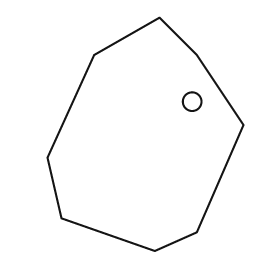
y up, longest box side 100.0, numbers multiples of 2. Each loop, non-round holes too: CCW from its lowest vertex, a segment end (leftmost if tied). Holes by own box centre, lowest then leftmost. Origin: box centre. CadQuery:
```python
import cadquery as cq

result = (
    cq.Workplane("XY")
    .moveTo(4.0, -50.0)
    .lineTo(22.0, -42.0)
    .lineTo(42.0, 4.0)
    .lineTo(22.0, 34.0)
    .lineTo(6.0, 50.0)
    .lineTo(-22.0, 34.0)
    .lineTo(-42.0, -10.0)
    .lineTo(-36.0, -36.0)
    .close()
    .moveTo(20.0, 14.0)
    .circle(4.0)
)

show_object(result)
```